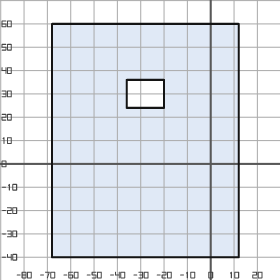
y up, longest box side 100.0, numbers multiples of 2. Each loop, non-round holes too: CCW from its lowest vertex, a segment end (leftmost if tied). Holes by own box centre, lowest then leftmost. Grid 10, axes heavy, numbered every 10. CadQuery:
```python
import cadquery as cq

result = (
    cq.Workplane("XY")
    .moveTo(-68.0, -40.0)
    .lineTo(12.0, -40.0)
    .lineTo(12.0, 60.0)
    .lineTo(-68.0, 60.0)
    .close()
    .moveTo(-36.0, 24.0)
    .lineTo(-20.0, 24.0)
    .lineTo(-20.0, 36.0)
    .lineTo(-36.0, 36.0)
    .close()
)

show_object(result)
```